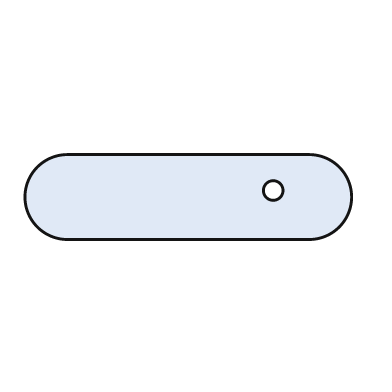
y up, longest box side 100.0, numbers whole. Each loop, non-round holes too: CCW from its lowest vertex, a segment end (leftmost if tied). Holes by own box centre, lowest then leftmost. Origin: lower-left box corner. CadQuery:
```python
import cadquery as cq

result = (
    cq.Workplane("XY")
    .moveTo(13.0, 0.0)
    .lineTo(87.0, 0.0)
    .threePointArc((100.0, 13.0), (87.0, 26.0))
    .lineTo(13.0, 26.0)
    .threePointArc((0.0, 13.0), (13.0, 0.0))
    .close()
    .moveTo(76.0, 15.0)
    .circle(3.0)
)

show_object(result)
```